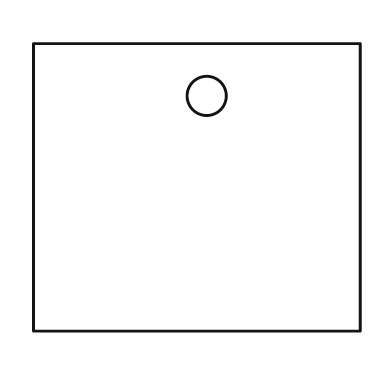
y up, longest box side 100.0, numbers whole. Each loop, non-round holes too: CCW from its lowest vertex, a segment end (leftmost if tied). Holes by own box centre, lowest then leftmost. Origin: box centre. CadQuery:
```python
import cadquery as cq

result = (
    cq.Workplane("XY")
    .moveTo(-50.0, -44.0)
    .lineTo(50.0, -44.0)
    .lineTo(50.0, 44.0)
    .lineTo(-50.0, 44.0)
    .close()
    .moveTo(3.0, 28.0)
    .circle(6.0)
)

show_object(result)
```